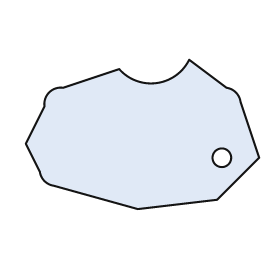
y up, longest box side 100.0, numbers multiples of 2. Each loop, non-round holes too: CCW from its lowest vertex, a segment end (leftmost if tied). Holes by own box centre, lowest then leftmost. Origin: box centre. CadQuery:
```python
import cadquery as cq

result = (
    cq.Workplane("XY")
    .moveTo(-2.0, -32.0)
    .lineTo(32.0, -28.0)
    .lineTo(50.0, -10.0)
    .lineTo(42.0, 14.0)
    .threePointArc((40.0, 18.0), (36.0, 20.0))
    .lineTo(20.0, 32.0)
    .threePointArc((6.0, 22.0), (-10.0, 28.0))
    .lineTo(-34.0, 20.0)
    .threePointArc((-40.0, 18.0), (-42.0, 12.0))
    .lineTo(-50.0, -4.0)
    .lineTo(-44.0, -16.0)
    .threePointArc((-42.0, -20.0), (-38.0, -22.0))
    .close()
    .moveTo(34.0, -10.0)
    .circle(4.0)
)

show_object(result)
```